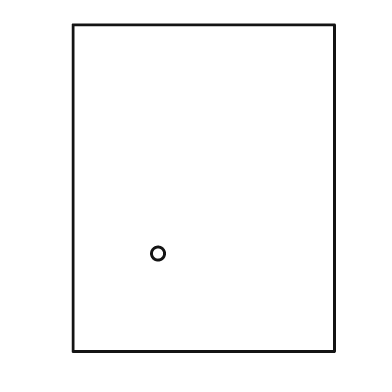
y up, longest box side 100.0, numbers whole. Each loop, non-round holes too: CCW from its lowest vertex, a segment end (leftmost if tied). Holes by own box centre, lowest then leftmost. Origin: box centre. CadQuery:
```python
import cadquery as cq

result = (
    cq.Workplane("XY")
    .moveTo(-40.0, -50.0)
    .lineTo(40.0, -50.0)
    .lineTo(40.0, 50.0)
    .lineTo(-40.0, 50.0)
    .close()
    .moveTo(-14.0, -20.0)
    .circle(2.0)
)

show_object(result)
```